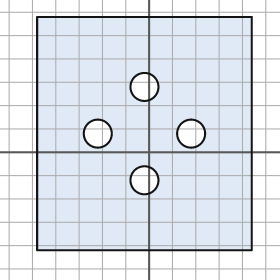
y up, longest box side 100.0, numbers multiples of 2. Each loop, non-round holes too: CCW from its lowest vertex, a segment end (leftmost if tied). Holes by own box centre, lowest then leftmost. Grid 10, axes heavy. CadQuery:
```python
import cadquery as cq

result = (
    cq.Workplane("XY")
    .moveTo(-48.0, -42.0)
    .lineTo(44.0, -42.0)
    .lineTo(44.0, 58.0)
    .lineTo(-48.0, 58.0)
    .close()
    .moveTo(-2.0, -12.0)
    .circle(6.0)
    .moveTo(-22.0, 8.0)
    .circle(6.0)
    .moveTo(18.0, 8.0)
    .circle(6.0)
    .moveTo(-2.0, 28.0)
    .circle(6.0)
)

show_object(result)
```